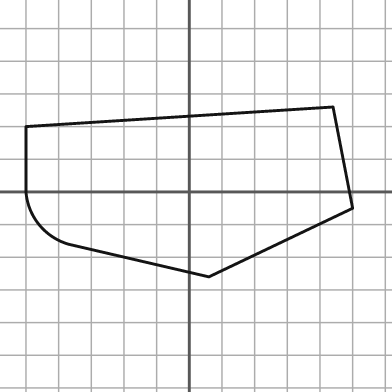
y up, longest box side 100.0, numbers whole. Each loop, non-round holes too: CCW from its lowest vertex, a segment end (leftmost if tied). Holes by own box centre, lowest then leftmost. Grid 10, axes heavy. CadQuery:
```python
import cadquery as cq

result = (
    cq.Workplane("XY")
    .moveTo(6.0, -26.0)
    .lineTo(50.0, -5.0)
    .lineTo(44.0, 26.0)
    .lineTo(-50.0, 20.0)
    .lineTo(-50.0, 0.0)
    .threePointArc((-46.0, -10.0), (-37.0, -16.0))
    .close()
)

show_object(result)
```